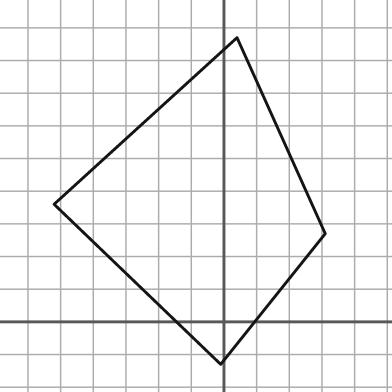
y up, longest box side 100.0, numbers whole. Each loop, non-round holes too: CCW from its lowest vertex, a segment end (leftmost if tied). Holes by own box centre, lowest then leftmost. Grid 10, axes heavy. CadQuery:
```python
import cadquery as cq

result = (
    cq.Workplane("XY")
    .moveTo(-1.0, -13.0)
    .lineTo(31.0, 27.0)
    .lineTo(4.0, 87.0)
    .lineTo(-52.0, 36.0)
    .close()
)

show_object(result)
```